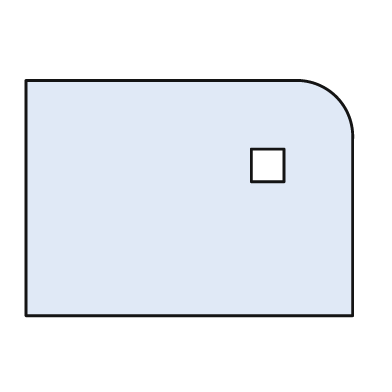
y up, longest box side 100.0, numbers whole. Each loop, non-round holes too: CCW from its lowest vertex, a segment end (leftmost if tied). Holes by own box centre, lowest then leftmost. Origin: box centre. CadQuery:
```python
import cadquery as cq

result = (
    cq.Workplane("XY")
    .moveTo(-50.0, -36.0)
    .lineTo(50.0, -36.0)
    .lineTo(50.0, 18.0)
    .threePointArc((45.0, 31.0), (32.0, 36.0))
    .lineTo(-50.0, 36.0)
    .close()
    .moveTo(19.0, 5.0)
    .lineTo(29.0, 5.0)
    .lineTo(29.0, 15.0)
    .lineTo(19.0, 15.0)
    .close()
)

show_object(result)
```